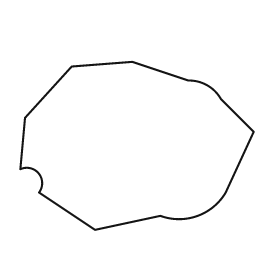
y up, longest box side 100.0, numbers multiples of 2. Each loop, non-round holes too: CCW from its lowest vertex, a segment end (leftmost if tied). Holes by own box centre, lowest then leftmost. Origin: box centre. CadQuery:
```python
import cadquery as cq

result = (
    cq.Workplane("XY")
    .moveTo(-18.0, -36.0)
    .lineTo(10.0, -30.0)
    .threePointArc((26.0, -30.0), (38.0, -20.0))
    .lineTo(50.0, 6.0)
    .lineTo(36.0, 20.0)
    .threePointArc((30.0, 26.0), (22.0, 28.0))
    .lineTo(-2.0, 36.0)
    .lineTo(-28.0, 34.0)
    .lineTo(-48.0, 12.0)
    .lineTo(-50.0, -10.0)
    .threePointArc((-42.0, -12.0), (-42.0, -20.0))
    .close()
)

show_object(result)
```